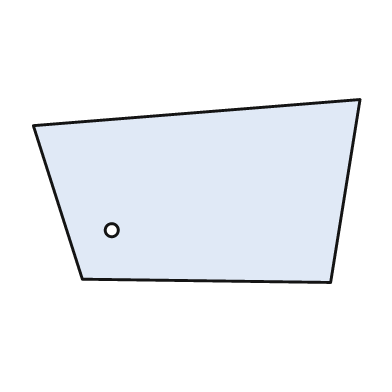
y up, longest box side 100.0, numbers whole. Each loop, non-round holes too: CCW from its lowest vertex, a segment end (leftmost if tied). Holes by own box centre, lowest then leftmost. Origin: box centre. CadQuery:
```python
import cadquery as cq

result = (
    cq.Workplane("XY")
    .moveTo(41.0, -28.0)
    .lineTo(50.0, 28.0)
    .lineTo(-50.0, 20.0)
    .lineTo(-35.0, -27.0)
    .close()
    .moveTo(-26.0, -12.0)
    .circle(2.0)
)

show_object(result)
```